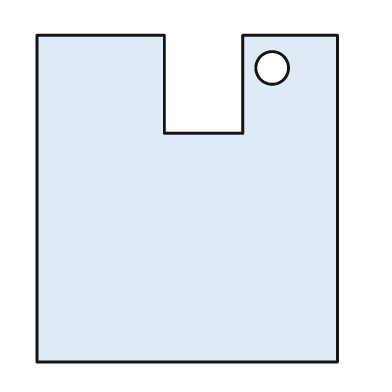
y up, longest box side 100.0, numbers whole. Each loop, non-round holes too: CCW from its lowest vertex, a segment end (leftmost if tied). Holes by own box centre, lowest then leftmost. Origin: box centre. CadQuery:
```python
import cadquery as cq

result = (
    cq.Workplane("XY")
    .moveTo(-46.0, -50.0)
    .lineTo(46.0, -50.0)
    .lineTo(46.0, 50.0)
    .lineTo(17.0, 50.0)
    .lineTo(17.0, 20.0)
    .lineTo(-7.0, 20.0)
    .lineTo(-7.0, 50.0)
    .lineTo(-46.0, 50.0)
    .close()
    .moveTo(26.0, 40.0)
    .circle(5.0)
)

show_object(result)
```